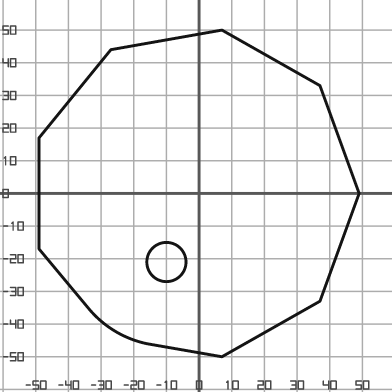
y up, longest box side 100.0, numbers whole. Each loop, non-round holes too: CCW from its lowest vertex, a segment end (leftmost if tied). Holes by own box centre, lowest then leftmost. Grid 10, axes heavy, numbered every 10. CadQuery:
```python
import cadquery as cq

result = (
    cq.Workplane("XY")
    .moveTo(7.0, -50.0)
    .lineTo(37.0, -33.0)
    .lineTo(49.0, 0.0)
    .lineTo(37.0, 33.0)
    .lineTo(7.0, 50.0)
    .lineTo(-27.0, 44.0)
    .lineTo(-49.0, 17.0)
    .lineTo(-49.0, -17.0)
    .lineTo(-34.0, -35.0)
    .threePointArc((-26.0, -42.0), (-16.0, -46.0))
    .close()
    .moveTo(-10.0, -21.0)
    .circle(6.0)
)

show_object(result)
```